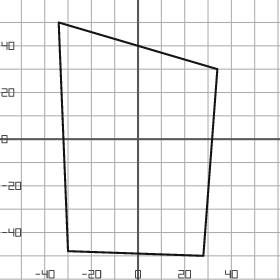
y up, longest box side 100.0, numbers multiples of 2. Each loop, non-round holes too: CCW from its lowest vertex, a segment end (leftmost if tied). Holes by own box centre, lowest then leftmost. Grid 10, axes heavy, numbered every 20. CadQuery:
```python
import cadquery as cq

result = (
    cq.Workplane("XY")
    .moveTo(28.0, -50.0)
    .lineTo(34.0, 30.0)
    .lineTo(-34.0, 50.0)
    .lineTo(-30.0, -48.0)
    .close()
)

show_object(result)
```